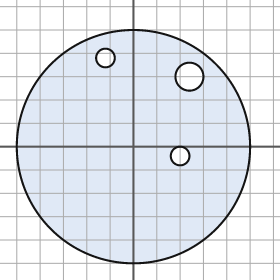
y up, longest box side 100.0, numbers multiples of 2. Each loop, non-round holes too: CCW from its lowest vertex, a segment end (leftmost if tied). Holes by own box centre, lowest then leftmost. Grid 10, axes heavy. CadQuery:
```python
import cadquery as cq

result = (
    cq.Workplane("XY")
    .moveTo(0.0, 0.0)
    .circle(50.0)
    .moveTo(20.0, -4.0)
    .circle(4.0)
    .moveTo(24.0, 30.0)
    .circle(6.0)
    .moveTo(-12.0, 38.0)
    .circle(4.0)
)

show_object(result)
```